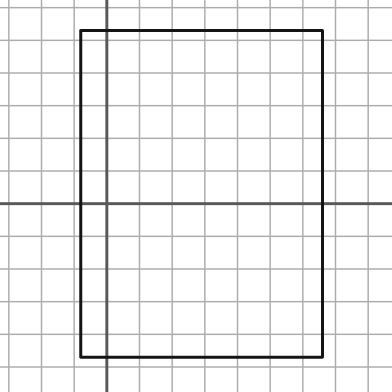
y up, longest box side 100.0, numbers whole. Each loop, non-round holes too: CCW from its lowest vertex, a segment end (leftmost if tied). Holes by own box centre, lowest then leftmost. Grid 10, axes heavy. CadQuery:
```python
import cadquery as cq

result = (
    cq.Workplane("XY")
    .moveTo(-8.0, -47.0)
    .lineTo(66.0, -47.0)
    .lineTo(66.0, 53.0)
    .lineTo(-8.0, 53.0)
    .close()
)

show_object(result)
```